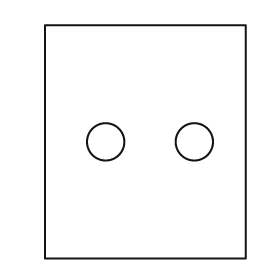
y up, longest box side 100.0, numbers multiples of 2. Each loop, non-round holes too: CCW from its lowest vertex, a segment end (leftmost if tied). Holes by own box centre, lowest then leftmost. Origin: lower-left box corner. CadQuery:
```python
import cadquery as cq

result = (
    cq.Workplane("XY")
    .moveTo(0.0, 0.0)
    .lineTo(86.0, 0.0)
    .lineTo(86.0, 100.0)
    .lineTo(0.0, 100.0)
    .close()
    .moveTo(26.0, 50.0)
    .circle(8.0)
    .moveTo(64.0, 50.0)
    .circle(8.0)
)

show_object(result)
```